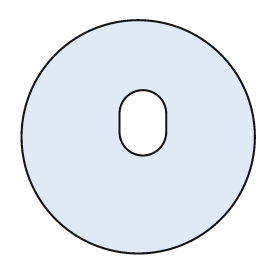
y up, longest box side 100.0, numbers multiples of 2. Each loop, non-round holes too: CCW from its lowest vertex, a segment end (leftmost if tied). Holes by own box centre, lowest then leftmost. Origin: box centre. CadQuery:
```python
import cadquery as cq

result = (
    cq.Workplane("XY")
    .moveTo(0.0, 0.0)
    .circle(50.0)
    .moveTo(-8.0, 2.0)
    .threePointArc((2.0, -8.0), (12.0, 2.0))
    .lineTo(12.0, 10.0)
    .threePointArc((2.0, 20.0), (-8.0, 10.0))
    .close()
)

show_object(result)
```